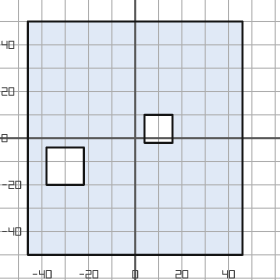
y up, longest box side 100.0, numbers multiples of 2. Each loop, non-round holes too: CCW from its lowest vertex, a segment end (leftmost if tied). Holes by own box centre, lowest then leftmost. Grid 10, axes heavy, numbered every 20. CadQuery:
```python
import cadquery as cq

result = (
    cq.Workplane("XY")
    .moveTo(-46.0, -50.0)
    .lineTo(46.0, -50.0)
    .lineTo(46.0, 50.0)
    .lineTo(-46.0, 50.0)
    .close()
    .moveTo(-38.0, -20.0)
    .lineTo(-22.0, -20.0)
    .lineTo(-22.0, -4.0)
    .lineTo(-38.0, -4.0)
    .close()
    .moveTo(4.0, -2.0)
    .lineTo(16.0, -2.0)
    .lineTo(16.0, 10.0)
    .lineTo(4.0, 10.0)
    .close()
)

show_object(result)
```